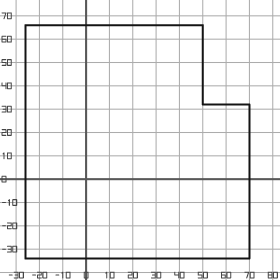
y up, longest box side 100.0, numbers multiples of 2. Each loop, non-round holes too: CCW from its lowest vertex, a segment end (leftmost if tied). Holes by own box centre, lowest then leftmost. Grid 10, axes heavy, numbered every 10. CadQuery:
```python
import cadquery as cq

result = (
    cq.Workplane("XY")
    .moveTo(-26.0, -34.0)
    .lineTo(70.0, -34.0)
    .lineTo(70.0, 32.0)
    .lineTo(50.0, 32.0)
    .lineTo(50.0, 66.0)
    .lineTo(-26.0, 66.0)
    .close()
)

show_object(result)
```